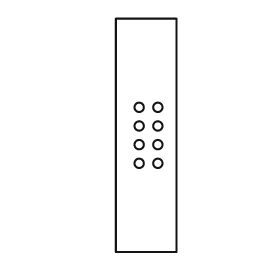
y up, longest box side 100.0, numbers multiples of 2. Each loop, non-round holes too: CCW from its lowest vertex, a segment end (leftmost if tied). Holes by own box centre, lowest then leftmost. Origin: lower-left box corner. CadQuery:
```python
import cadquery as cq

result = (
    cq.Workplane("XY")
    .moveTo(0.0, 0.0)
    .lineTo(26.0, 0.0)
    .lineTo(26.0, 100.0)
    .lineTo(0.0, 100.0)
    .close()
    .moveTo(10.0, 38.0)
    .circle(2.0)
    .moveTo(18.0, 38.0)
    .circle(2.0)
    .moveTo(10.0, 46.0)
    .circle(2.0)
    .moveTo(18.0, 46.0)
    .circle(2.0)
    .moveTo(10.0, 54.0)
    .circle(2.0)
    .moveTo(18.0, 54.0)
    .circle(2.0)
    .moveTo(10.0, 62.0)
    .circle(2.0)
    .moveTo(18.0, 62.0)
    .circle(2.0)
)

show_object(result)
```